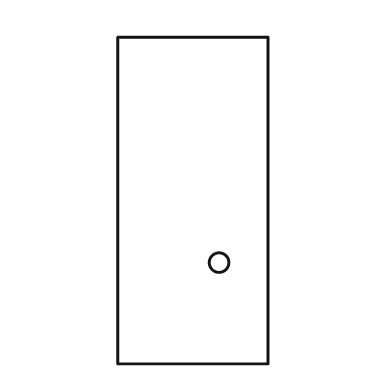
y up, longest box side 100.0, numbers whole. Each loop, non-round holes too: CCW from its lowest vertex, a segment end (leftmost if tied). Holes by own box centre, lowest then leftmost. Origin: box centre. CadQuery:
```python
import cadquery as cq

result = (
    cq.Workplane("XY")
    .moveTo(-23.0, -50.0)
    .lineTo(23.0, -50.0)
    .lineTo(23.0, 50.0)
    .lineTo(-23.0, 50.0)
    .close()
    .moveTo(8.0, -19.0)
    .circle(3.0)
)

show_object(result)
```